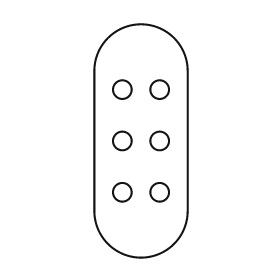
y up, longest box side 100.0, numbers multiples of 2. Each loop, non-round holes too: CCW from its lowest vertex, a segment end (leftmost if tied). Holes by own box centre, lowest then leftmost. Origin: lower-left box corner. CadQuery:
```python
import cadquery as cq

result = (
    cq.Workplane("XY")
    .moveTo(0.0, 20.0)
    .threePointArc((20.0, 0.0), (40.0, 20.0))
    .lineTo(40.0, 80.0)
    .threePointArc((20.0, 100.0), (0.0, 80.0))
    .close()
    .moveTo(12.0, 28.0)
    .circle(4.0)
    .moveTo(28.0, 28.0)
    .circle(4.0)
    .moveTo(12.0, 50.0)
    .circle(4.0)
    .moveTo(28.0, 50.0)
    .circle(4.0)
    .moveTo(12.0, 72.0)
    .circle(4.0)
    .moveTo(28.0, 72.0)
    .circle(4.0)
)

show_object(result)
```